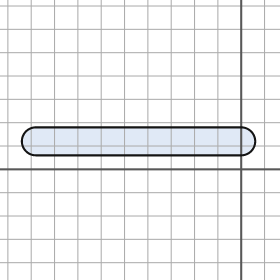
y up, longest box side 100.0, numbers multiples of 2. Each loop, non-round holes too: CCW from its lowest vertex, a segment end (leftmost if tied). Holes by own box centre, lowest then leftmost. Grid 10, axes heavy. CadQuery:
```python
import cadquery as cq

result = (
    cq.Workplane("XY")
    .moveTo(-88.0, 6.0)
    .lineTo(0.0, 6.0)
    .threePointArc((6.0, 12.0), (0.0, 18.0))
    .lineTo(-88.0, 18.0)
    .threePointArc((-94.0, 12.0), (-88.0, 6.0))
    .close()
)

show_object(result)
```